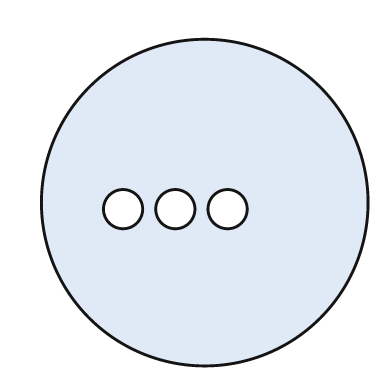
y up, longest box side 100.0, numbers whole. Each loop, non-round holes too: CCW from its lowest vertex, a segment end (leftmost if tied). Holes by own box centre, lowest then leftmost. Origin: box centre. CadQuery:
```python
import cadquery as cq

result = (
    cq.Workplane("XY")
    .moveTo(0.0, 0.0)
    .circle(50.0)
    .moveTo(-25.0, -2.0)
    .circle(6.0)
    .moveTo(-9.0, -2.0)
    .circle(6.0)
    .moveTo(7.0, -2.0)
    .circle(6.0)
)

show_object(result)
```